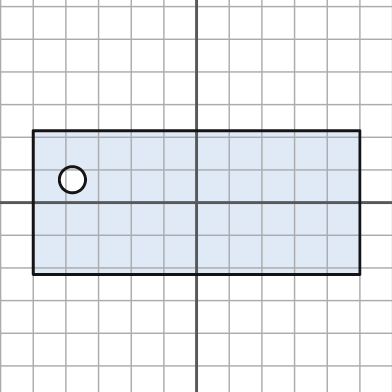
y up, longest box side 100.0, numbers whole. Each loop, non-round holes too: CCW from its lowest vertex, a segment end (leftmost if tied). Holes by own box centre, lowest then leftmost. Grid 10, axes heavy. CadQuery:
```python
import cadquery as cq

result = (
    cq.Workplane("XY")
    .moveTo(-50.0, -22.0)
    .lineTo(50.0, -22.0)
    .lineTo(50.0, 22.0)
    .lineTo(-50.0, 22.0)
    .close()
    .moveTo(-38.0, 7.0)
    .circle(4.0)
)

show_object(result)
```